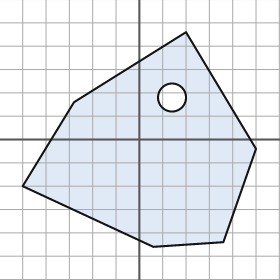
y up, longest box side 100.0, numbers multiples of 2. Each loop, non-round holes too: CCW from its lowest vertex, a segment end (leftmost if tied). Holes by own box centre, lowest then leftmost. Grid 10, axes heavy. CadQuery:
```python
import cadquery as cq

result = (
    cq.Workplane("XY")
    .moveTo(6.0, -46.0)
    .lineTo(36.0, -44.0)
    .lineTo(50.0, -4.0)
    .lineTo(20.0, 46.0)
    .lineTo(-28.0, 16.0)
    .lineTo(-50.0, -20.0)
    .close()
    .moveTo(14.0, 18.0)
    .circle(6.0)
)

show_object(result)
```